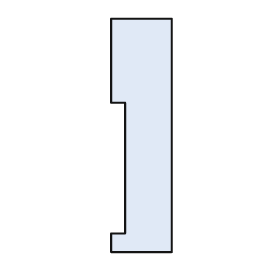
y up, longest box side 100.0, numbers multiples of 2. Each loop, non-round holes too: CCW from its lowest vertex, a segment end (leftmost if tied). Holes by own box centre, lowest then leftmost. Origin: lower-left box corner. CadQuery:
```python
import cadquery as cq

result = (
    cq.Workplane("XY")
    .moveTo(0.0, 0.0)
    .lineTo(26.0, 0.0)
    .lineTo(26.0, 100.0)
    .lineTo(0.0, 100.0)
    .lineTo(0.0, 64.0)
    .lineTo(6.0, 64.0)
    .lineTo(6.0, 8.0)
    .lineTo(0.0, 8.0)
    .close()
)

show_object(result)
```